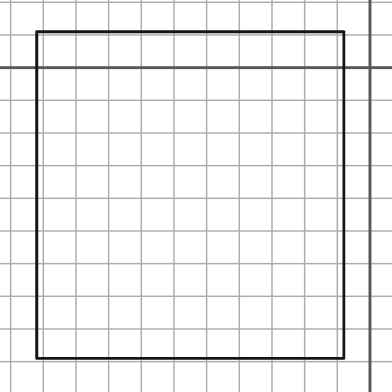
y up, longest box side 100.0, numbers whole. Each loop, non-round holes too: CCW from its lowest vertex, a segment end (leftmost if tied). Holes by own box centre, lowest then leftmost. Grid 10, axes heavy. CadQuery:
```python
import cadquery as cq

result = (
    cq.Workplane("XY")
    .moveTo(-102.0, -89.0)
    .lineTo(-8.0, -89.0)
    .lineTo(-8.0, 11.0)
    .lineTo(-102.0, 11.0)
    .close()
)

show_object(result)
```